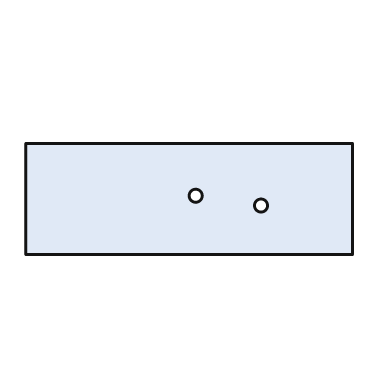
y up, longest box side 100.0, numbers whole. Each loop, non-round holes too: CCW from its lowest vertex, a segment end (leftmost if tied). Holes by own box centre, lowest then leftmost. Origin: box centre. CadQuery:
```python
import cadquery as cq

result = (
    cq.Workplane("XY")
    .moveTo(-50.0, -17.0)
    .lineTo(50.0, -17.0)
    .lineTo(50.0, 17.0)
    .lineTo(-50.0, 17.0)
    .close()
    .moveTo(22.0, -2.0)
    .circle(2.0)
    .moveTo(2.0, 1.0)
    .circle(2.0)
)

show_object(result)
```